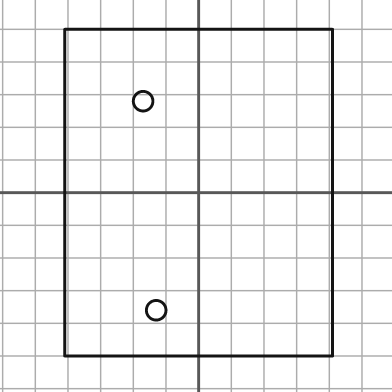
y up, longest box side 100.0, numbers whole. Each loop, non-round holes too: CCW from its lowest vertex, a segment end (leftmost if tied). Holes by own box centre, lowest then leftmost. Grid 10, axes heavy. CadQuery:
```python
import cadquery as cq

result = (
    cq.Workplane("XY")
    .moveTo(-41.0, -50.0)
    .lineTo(41.0, -50.0)
    .lineTo(41.0, 50.0)
    .lineTo(-41.0, 50.0)
    .close()
    .moveTo(-13.0, -36.0)
    .circle(3.0)
    .moveTo(-17.0, 28.0)
    .circle(3.0)
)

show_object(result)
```